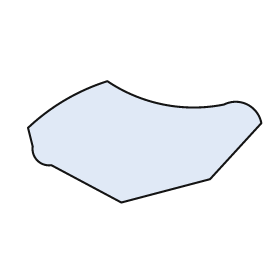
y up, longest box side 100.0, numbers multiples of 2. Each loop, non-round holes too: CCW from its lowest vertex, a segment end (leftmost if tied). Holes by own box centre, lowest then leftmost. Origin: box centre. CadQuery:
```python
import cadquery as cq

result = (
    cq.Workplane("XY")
    .moveTo(-10.0, -26.0)
    .lineTo(28.0, -16.0)
    .lineTo(50.0, 8.0)
    .threePointArc((44.0, 16.0), (34.0, 16.0))
    .threePointArc((8.0, 16.0), (-16.0, 26.0))
    .threePointArc((-34.0, 18.0), (-50.0, 6.0))
    .lineTo(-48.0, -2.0)
    .threePointArc((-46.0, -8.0), (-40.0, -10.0))
    .close()
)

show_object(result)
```